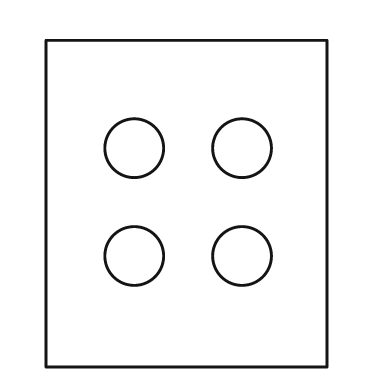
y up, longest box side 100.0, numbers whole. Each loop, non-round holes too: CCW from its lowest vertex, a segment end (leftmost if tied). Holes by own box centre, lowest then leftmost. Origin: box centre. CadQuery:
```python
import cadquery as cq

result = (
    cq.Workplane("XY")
    .moveTo(-43.0, -50.0)
    .lineTo(43.0, -50.0)
    .lineTo(43.0, 50.0)
    .lineTo(-43.0, 50.0)
    .close()
    .moveTo(-16.0, -16.0)
    .circle(9.0)
    .moveTo(17.0, -16.0)
    .circle(9.0)
    .moveTo(-16.0, 17.0)
    .circle(9.0)
    .moveTo(17.0, 17.0)
    .circle(9.0)
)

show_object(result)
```